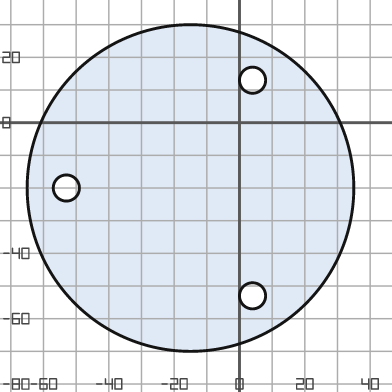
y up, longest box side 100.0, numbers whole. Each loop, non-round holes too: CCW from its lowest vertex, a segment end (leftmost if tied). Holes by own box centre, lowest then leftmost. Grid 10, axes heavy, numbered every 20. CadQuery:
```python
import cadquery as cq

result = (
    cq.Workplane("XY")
    .moveTo(-15.0, -20.0)
    .circle(50.0)
    .moveTo(4.0, -53.0)
    .circle(4.0)
    .moveTo(-53.0, -20.0)
    .circle(4.0)
    .moveTo(4.0, 13.0)
    .circle(4.0)
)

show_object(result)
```